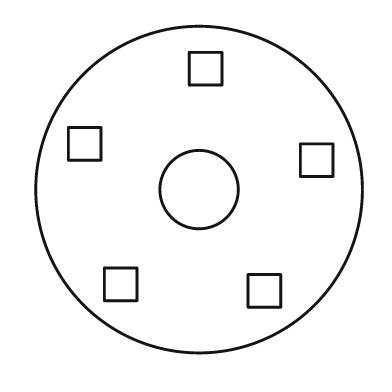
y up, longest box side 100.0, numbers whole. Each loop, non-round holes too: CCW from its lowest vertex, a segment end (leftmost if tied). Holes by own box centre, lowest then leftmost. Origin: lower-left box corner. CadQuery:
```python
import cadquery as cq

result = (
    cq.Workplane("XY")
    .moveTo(50.0, 50.0)
    .circle(50.0)
    .moveTo(65.0, 14.0)
    .lineTo(75.0, 14.0)
    .lineTo(75.0, 24.0)
    .lineTo(65.0, 24.0)
    .close()
    .moveTo(21.0, 16.0)
    .lineTo(31.0, 16.0)
    .lineTo(31.0, 26.0)
    .lineTo(21.0, 26.0)
    .close()
    .moveTo(50.0, 50.0)
    .circle(12.0)
    .moveTo(81.0, 54.0)
    .lineTo(91.0, 54.0)
    .lineTo(91.0, 64.0)
    .lineTo(81.0, 64.0)
    .close()
    .moveTo(10.0, 59.0)
    .lineTo(20.0, 59.0)
    .lineTo(20.0, 69.0)
    .lineTo(10.0, 69.0)
    .close()
    .moveTo(47.0, 82.0)
    .lineTo(57.0, 82.0)
    .lineTo(57.0, 92.0)
    .lineTo(47.0, 92.0)
    .close()
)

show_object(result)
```